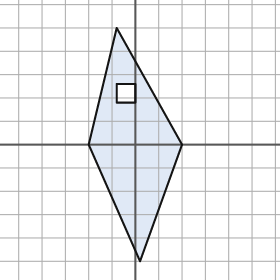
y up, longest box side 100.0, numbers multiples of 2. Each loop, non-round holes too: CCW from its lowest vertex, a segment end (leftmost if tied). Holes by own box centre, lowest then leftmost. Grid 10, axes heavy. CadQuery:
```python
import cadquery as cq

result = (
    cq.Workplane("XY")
    .moveTo(2.0, -50.0)
    .lineTo(20.0, 0.0)
    .lineTo(-8.0, 50.0)
    .lineTo(-20.0, 0.0)
    .close()
    .moveTo(-8.0, 18.0)
    .lineTo(0.0, 18.0)
    .lineTo(0.0, 26.0)
    .lineTo(-8.0, 26.0)
    .close()
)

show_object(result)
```